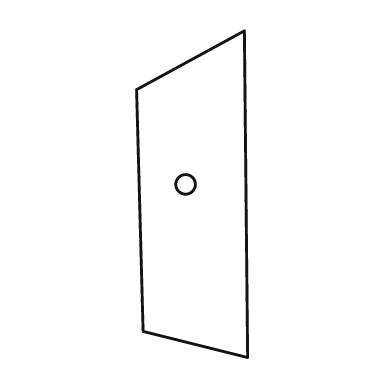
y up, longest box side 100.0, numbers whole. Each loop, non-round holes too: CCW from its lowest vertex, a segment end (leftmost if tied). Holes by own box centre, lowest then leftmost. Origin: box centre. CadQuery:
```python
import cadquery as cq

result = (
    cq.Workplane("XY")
    .moveTo(17.0, -50.0)
    .lineTo(16.0, 50.0)
    .lineTo(-17.0, 32.0)
    .lineTo(-15.0, -42.0)
    .close()
    .moveTo(-2.0, 3.0)
    .circle(3.0)
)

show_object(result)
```